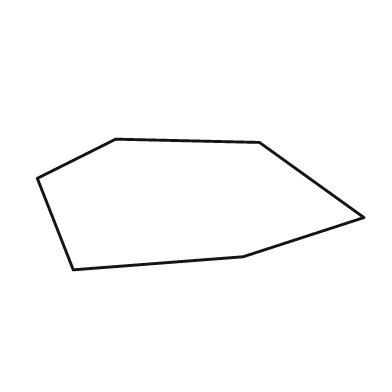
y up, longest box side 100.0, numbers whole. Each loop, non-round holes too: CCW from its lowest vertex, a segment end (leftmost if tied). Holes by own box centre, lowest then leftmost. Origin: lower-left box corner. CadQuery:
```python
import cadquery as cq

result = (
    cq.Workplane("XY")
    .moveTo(11.0, 0.0)
    .lineTo(63.0, 4.0)
    .lineTo(100.0, 16.0)
    .lineTo(68.0, 39.0)
    .lineTo(24.0, 40.0)
    .lineTo(0.0, 28.0)
    .close()
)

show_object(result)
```